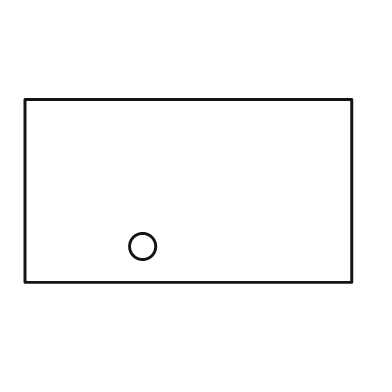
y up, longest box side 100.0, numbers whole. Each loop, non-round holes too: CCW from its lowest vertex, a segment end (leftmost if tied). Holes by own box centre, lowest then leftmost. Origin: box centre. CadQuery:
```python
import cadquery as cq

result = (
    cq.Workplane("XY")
    .moveTo(-50.0, -28.0)
    .lineTo(50.0, -28.0)
    .lineTo(50.0, 28.0)
    .lineTo(-50.0, 28.0)
    .close()
    .moveTo(-14.0, -17.0)
    .circle(4.0)
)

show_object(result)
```